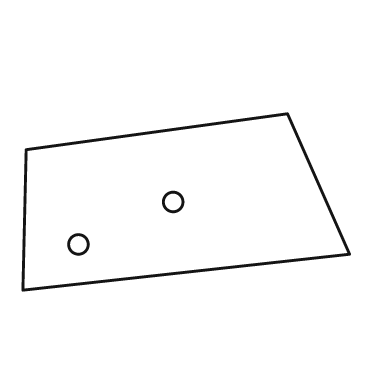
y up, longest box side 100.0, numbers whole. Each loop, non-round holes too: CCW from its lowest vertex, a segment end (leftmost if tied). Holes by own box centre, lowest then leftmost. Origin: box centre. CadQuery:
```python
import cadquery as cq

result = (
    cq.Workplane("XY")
    .moveTo(-50.0, -27.0)
    .lineTo(50.0, -16.0)
    .lineTo(31.0, 27.0)
    .lineTo(-49.0, 16.0)
    .close()
    .moveTo(-33.0, -13.0)
    .circle(3.0)
    .moveTo(-4.0, 0.0)
    .circle(3.0)
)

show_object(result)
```